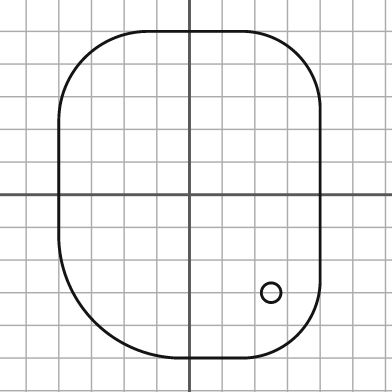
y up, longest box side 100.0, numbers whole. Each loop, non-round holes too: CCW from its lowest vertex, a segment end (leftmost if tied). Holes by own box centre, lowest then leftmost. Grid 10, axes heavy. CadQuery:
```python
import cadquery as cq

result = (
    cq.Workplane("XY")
    .moveTo(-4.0, -50.0)
    .lineTo(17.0, -50.0)
    .threePointArc((33.0, -43.0), (40.0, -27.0))
    .lineTo(40.0, 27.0)
    .threePointArc((33.0, 43.0), (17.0, 50.0))
    .lineTo(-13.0, 50.0)
    .threePointArc((-32.0, 42.0), (-40.0, 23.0))
    .lineTo(-40.0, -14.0)
    .threePointArc((-29.0, -39.0), (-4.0, -50.0))
    .close()
    .moveTo(25.0, -30.0)
    .circle(3.0)
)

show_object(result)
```